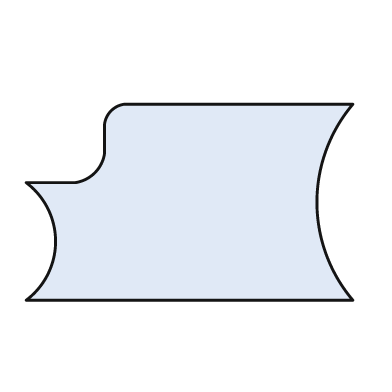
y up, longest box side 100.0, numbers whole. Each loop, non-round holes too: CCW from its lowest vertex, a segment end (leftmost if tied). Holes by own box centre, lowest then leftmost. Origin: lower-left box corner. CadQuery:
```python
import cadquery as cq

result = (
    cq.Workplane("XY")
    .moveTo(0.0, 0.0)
    .lineTo(100.0, 0.0)
    .threePointArc((89.0, 30.0), (100.0, 60.0))
    .lineTo(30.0, 60.0)
    .threePointArc((26.0, 58.0), (24.0, 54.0))
    .lineTo(24.0, 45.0)
    .threePointArc((21.0, 39.0), (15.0, 36.0))
    .lineTo(0.0, 36.0)
    .threePointArc((9.0, 18.0), (0.0, 0.0))
    .close()
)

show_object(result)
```